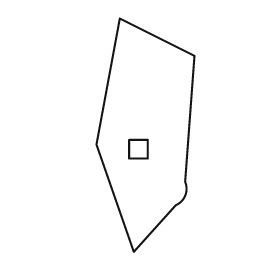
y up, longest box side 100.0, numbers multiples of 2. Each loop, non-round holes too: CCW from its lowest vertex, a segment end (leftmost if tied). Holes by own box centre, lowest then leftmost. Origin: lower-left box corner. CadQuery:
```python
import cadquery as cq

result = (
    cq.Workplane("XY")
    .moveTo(16.0, 0.0)
    .lineTo(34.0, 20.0)
    .threePointArc((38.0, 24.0), (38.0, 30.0))
    .lineTo(42.0, 84.0)
    .lineTo(10.0, 100.0)
    .lineTo(0.0, 46.0)
    .close()
    .moveTo(14.0, 40.0)
    .lineTo(22.0, 40.0)
    .lineTo(22.0, 48.0)
    .lineTo(14.0, 48.0)
    .close()
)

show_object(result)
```